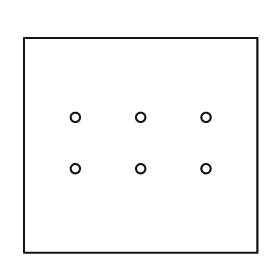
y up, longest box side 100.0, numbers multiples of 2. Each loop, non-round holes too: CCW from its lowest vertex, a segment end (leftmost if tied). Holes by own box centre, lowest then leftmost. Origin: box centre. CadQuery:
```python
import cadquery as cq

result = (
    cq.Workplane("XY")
    .moveTo(-50.0, -46.0)
    .lineTo(50.0, -46.0)
    .lineTo(50.0, 46.0)
    .lineTo(-50.0, 46.0)
    .close()
    .moveTo(-28.0, -10.0)
    .circle(2.0)
    .moveTo(0.0, -10.0)
    .circle(2.0)
    .moveTo(28.0, -10.0)
    .circle(2.0)
    .moveTo(-28.0, 12.0)
    .circle(2.0)
    .moveTo(0.0, 12.0)
    .circle(2.0)
    .moveTo(28.0, 12.0)
    .circle(2.0)
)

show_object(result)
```